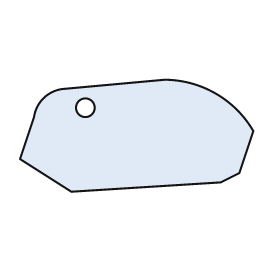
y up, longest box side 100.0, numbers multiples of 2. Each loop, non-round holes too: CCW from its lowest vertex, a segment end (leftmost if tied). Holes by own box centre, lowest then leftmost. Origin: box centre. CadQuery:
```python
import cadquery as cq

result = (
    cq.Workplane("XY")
    .moveTo(-28.0, -24.0)
    .lineTo(36.0, -20.0)
    .lineTo(44.0, -16.0)
    .lineTo(50.0, 2.0)
    .threePointArc((34.0, 18.0), (12.0, 24.0))
    .lineTo(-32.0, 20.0)
    .threePointArc((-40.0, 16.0), (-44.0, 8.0))
    .lineTo(-50.0, -10.0)
    .close()
    .moveTo(-22.0, 12.0)
    .circle(4.0)
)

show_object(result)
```